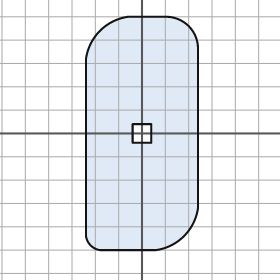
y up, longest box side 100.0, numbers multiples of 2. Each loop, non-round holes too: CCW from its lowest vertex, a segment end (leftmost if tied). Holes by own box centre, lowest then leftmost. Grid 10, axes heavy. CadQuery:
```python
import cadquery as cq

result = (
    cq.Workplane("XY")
    .moveTo(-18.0, -50.0)
    .lineTo(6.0, -50.0)
    .threePointArc((18.0, -44.0), (24.0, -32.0))
    .lineTo(24.0, 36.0)
    .threePointArc((20.0, 46.0), (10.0, 50.0))
    .lineTo(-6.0, 50.0)
    .threePointArc((-18.0, 44.0), (-24.0, 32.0))
    .lineTo(-24.0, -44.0)
    .threePointArc((-22.0, -48.0), (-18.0, -50.0))
    .close()
    .moveTo(-4.0, -4.0)
    .lineTo(4.0, -4.0)
    .lineTo(4.0, 4.0)
    .lineTo(-4.0, 4.0)
    .close()
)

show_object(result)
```